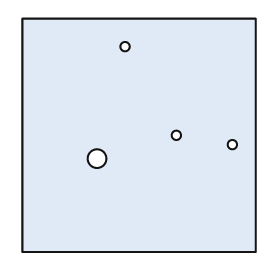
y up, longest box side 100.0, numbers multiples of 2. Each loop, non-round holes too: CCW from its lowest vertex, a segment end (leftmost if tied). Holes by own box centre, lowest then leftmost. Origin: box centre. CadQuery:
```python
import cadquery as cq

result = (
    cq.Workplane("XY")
    .moveTo(-50.0, -50.0)
    .lineTo(50.0, -50.0)
    .lineTo(50.0, 50.0)
    .lineTo(-50.0, 50.0)
    .close()
    .moveTo(-18.0, -10.0)
    .circle(4.0)
    .moveTo(40.0, -4.0)
    .circle(2.0)
    .moveTo(16.0, 0.0)
    .circle(2.0)
    .moveTo(-6.0, 38.0)
    .circle(2.0)
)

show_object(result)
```